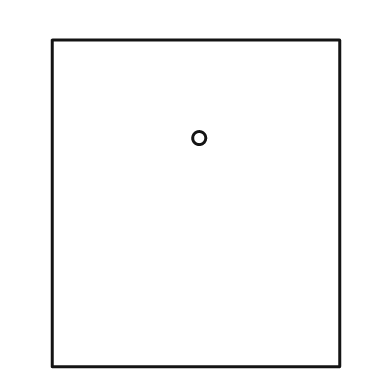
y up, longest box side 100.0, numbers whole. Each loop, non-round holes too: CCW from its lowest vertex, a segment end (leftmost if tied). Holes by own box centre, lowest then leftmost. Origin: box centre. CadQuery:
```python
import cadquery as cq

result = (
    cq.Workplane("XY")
    .moveTo(-44.0, -50.0)
    .lineTo(44.0, -50.0)
    .lineTo(44.0, 50.0)
    .lineTo(-44.0, 50.0)
    .close()
    .moveTo(1.0, 20.0)
    .circle(2.0)
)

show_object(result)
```